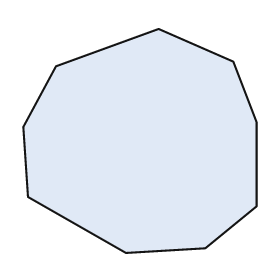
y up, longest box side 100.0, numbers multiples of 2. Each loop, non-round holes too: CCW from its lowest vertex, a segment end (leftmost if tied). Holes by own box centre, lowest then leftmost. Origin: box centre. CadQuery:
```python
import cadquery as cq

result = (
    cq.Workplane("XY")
    .moveTo(-6.0, -48.0)
    .lineTo(28.0, -46.0)
    .lineTo(50.0, -28.0)
    .lineTo(50.0, 8.0)
    .lineTo(40.0, 34.0)
    .lineTo(8.0, 48.0)
    .lineTo(-36.0, 32.0)
    .lineTo(-50.0, 6.0)
    .lineTo(-48.0, -24.0)
    .close()
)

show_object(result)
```